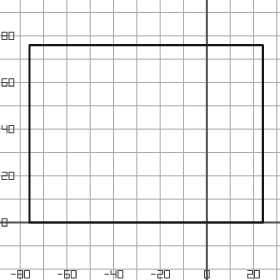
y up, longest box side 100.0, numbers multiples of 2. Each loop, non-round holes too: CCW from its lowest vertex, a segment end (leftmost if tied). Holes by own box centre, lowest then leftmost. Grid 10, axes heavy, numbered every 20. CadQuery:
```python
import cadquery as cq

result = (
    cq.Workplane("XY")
    .moveTo(-76.0, 0.0)
    .lineTo(24.0, 0.0)
    .lineTo(24.0, 76.0)
    .lineTo(-76.0, 76.0)
    .close()
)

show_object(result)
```